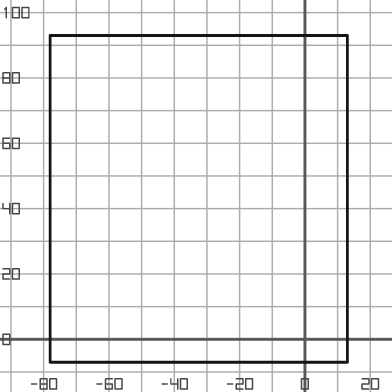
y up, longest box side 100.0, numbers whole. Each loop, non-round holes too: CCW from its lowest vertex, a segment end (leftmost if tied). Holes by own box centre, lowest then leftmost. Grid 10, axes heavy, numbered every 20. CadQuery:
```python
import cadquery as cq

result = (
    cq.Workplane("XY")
    .moveTo(-78.0, -7.0)
    .lineTo(13.0, -7.0)
    .lineTo(13.0, 93.0)
    .lineTo(-78.0, 93.0)
    .close()
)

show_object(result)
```